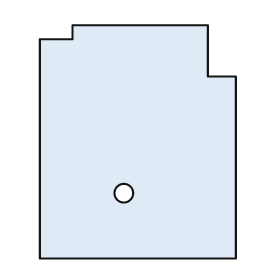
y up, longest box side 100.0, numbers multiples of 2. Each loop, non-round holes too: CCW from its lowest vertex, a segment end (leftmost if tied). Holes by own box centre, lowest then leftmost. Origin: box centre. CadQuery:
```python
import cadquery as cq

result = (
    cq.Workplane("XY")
    .moveTo(-42.0, -50.0)
    .lineTo(42.0, -50.0)
    .lineTo(42.0, 28.0)
    .lineTo(30.0, 28.0)
    .lineTo(30.0, 50.0)
    .lineTo(-28.0, 50.0)
    .lineTo(-28.0, 44.0)
    .lineTo(-42.0, 44.0)
    .close()
    .moveTo(-6.0, -22.0)
    .circle(4.0)
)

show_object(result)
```